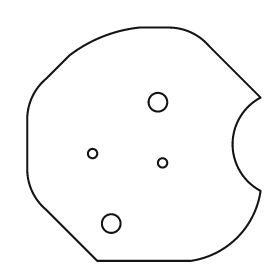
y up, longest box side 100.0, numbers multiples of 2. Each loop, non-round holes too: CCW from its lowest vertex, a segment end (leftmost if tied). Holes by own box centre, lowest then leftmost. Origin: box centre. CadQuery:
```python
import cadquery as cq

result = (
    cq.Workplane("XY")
    .moveTo(-20.0, -50.0)
    .lineTo(20.0, -50.0)
    .threePointArc((40.0, -40.0), (50.0, -20.0))
    .threePointArc((38.0, 0.0), (50.0, 20.0))
    .lineTo(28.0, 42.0)
    .threePointArc((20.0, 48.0), (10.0, 50.0))
    .lineTo(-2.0, 50.0)
    .threePointArc((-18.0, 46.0), (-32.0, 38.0))
    .lineTo(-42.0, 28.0)
    .threePointArc((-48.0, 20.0), (-50.0, 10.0))
    .lineTo(-50.0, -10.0)
    .threePointArc((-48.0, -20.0), (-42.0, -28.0))
    .close()
    .moveTo(-14.0, -34.0)
    .circle(4.0)
    .moveTo(8.0, -8.0)
    .circle(2.0)
    .moveTo(-22.0, -4.0)
    .circle(2.0)
    .moveTo(6.0, 18.0)
    .circle(4.0)
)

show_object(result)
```